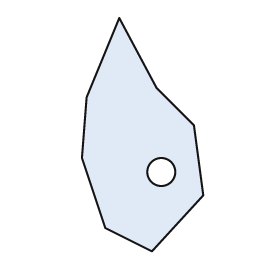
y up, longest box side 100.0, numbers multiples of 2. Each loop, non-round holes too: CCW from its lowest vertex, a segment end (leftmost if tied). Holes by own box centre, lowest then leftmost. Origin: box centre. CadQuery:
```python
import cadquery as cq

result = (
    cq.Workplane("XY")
    .moveTo(4.0, -50.0)
    .lineTo(26.0, -26.0)
    .lineTo(22.0, 4.0)
    .lineTo(6.0, 20.0)
    .lineTo(-10.0, 50.0)
    .lineTo(-24.0, 16.0)
    .lineTo(-26.0, -10.0)
    .lineTo(-16.0, -40.0)
    .close()
    .moveTo(8.0, -16.0)
    .circle(6.0)
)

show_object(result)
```